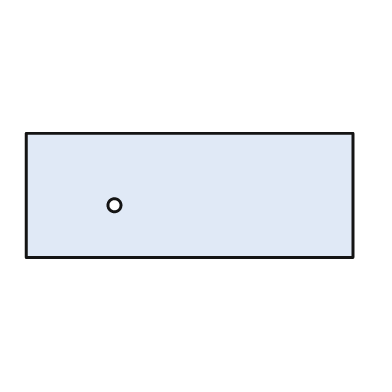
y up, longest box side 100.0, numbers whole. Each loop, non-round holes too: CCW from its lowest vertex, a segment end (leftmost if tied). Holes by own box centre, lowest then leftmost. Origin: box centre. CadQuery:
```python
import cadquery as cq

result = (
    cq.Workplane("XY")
    .moveTo(-50.0, -19.0)
    .lineTo(50.0, -19.0)
    .lineTo(50.0, 19.0)
    .lineTo(-50.0, 19.0)
    .close()
    .moveTo(-23.0, -3.0)
    .circle(2.0)
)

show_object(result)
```